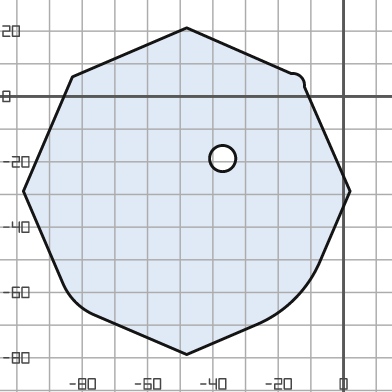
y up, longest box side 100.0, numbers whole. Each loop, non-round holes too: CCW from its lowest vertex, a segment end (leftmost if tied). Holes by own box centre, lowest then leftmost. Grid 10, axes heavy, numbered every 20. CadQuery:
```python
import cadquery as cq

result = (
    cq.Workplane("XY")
    .moveTo(-48.0, -79.0)
    .lineTo(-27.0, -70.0)
    .threePointArc((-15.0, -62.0), (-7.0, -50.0))
    .lineTo(2.0, -29.0)
    .lineTo(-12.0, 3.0)
    .threePointArc((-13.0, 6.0), (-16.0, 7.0))
    .lineTo(-48.0, 21.0)
    .lineTo(-83.0, 6.0)
    .lineTo(-98.0, -29.0)
    .lineTo(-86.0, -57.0)
    .threePointArc((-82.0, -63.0), (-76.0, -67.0))
    .close()
    .moveTo(-37.0, -19.0)
    .circle(4.0)
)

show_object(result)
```